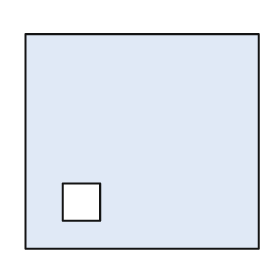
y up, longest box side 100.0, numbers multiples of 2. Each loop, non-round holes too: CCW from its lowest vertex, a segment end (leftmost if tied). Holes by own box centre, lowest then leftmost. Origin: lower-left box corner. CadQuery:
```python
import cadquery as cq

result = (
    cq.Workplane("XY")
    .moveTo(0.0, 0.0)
    .lineTo(100.0, 0.0)
    .lineTo(100.0, 92.0)
    .lineTo(0.0, 92.0)
    .close()
    .moveTo(16.0, 12.0)
    .lineTo(32.0, 12.0)
    .lineTo(32.0, 28.0)
    .lineTo(16.0, 28.0)
    .close()
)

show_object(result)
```